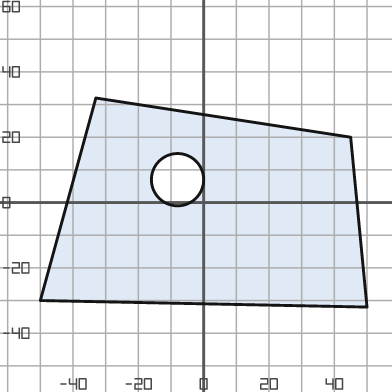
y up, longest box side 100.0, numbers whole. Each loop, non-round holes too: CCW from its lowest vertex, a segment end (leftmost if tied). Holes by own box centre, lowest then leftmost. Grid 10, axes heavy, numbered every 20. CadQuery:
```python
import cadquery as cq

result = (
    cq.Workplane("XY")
    .moveTo(50.0, -32.0)
    .lineTo(45.0, 20.0)
    .lineTo(-33.0, 32.0)
    .lineTo(-50.0, -30.0)
    .close()
    .moveTo(-8.0, 7.0)
    .circle(8.0)
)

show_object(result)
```